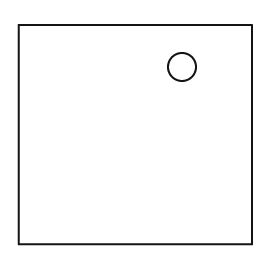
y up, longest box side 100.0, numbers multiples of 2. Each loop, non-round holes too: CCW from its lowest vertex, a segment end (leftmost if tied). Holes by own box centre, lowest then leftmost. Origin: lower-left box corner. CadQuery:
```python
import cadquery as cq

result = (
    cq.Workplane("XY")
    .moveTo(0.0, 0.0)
    .lineTo(100.0, 0.0)
    .lineTo(100.0, 94.0)
    .lineTo(0.0, 94.0)
    .close()
    .moveTo(70.0, 76.0)
    .circle(6.0)
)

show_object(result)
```